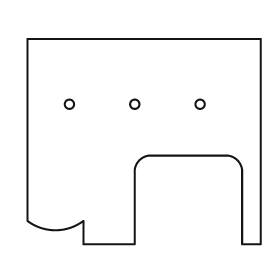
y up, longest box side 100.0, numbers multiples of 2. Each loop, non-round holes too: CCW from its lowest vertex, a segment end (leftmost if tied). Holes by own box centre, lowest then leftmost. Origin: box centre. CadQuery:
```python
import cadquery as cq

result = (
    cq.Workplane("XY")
    .moveTo(-26.0, -44.0)
    .lineTo(-4.0, -44.0)
    .lineTo(-4.0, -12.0)
    .threePointArc((-2.0, -8.0), (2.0, -6.0))
    .lineTo(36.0, -6.0)
    .threePointArc((40.0, -8.0), (42.0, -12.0))
    .lineTo(42.0, -44.0)
    .lineTo(50.0, -44.0)
    .lineTo(50.0, 44.0)
    .lineTo(-50.0, 44.0)
    .lineTo(-50.0, -34.0)
    .threePointArc((-38.0, -38.0), (-26.0, -34.0))
    .close()
    .moveTo(-32.0, 16.0)
    .circle(2.0)
    .moveTo(-4.0, 16.0)
    .circle(2.0)
    .moveTo(24.0, 16.0)
    .circle(2.0)
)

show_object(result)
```